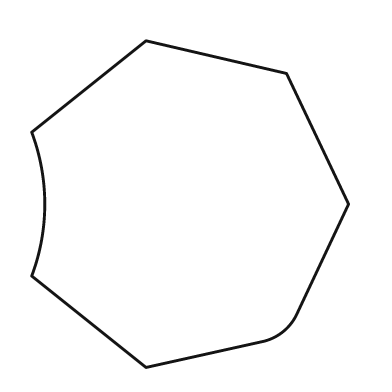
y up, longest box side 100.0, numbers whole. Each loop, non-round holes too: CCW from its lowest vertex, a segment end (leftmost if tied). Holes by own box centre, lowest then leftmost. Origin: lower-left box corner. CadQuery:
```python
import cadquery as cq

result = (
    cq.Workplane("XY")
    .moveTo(35.0, 0.0)
    .lineTo(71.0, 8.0)
    .threePointArc((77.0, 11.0), (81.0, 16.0))
    .lineTo(97.0, 50.0)
    .lineTo(78.0, 90.0)
    .lineTo(35.0, 100.0)
    .lineTo(0.0, 72.0)
    .threePointArc((4.0, 50.0), (0.0, 28.0))
    .close()
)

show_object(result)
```